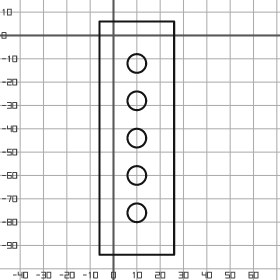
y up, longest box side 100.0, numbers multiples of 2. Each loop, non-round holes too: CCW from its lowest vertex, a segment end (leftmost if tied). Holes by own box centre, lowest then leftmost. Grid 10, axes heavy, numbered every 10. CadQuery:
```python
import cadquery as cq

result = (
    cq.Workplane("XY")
    .moveTo(-6.0, -94.0)
    .lineTo(26.0, -94.0)
    .lineTo(26.0, 6.0)
    .lineTo(-6.0, 6.0)
    .close()
    .moveTo(10.0, -76.0)
    .circle(4.0)
    .moveTo(10.0, -60.0)
    .circle(4.0)
    .moveTo(10.0, -44.0)
    .circle(4.0)
    .moveTo(10.0, -28.0)
    .circle(4.0)
    .moveTo(10.0, -12.0)
    .circle(4.0)
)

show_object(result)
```